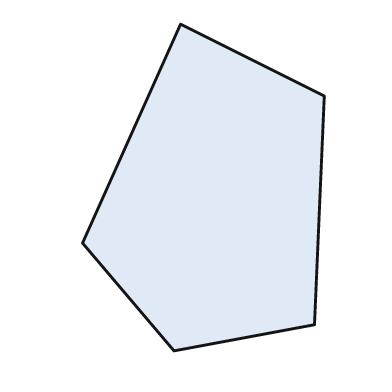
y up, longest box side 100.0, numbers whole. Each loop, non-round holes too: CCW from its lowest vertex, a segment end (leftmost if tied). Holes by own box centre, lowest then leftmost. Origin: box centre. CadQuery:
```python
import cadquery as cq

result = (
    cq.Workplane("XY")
    .moveTo(-9.0, -50.0)
    .lineTo(34.0, -42.0)
    .lineTo(37.0, 28.0)
    .lineTo(-7.0, 50.0)
    .lineTo(-37.0, -17.0)
    .close()
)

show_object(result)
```